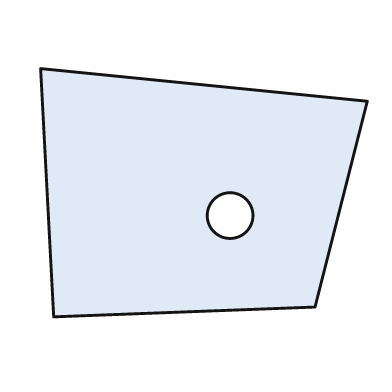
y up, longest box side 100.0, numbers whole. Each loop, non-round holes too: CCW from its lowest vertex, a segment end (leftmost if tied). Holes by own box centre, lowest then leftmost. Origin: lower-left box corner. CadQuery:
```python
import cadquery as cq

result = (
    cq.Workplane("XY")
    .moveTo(4.0, 0.0)
    .lineTo(84.0, 3.0)
    .lineTo(100.0, 66.0)
    .lineTo(0.0, 76.0)
    .close()
    .moveTo(58.0, 31.0)
    .circle(7.0)
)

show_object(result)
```